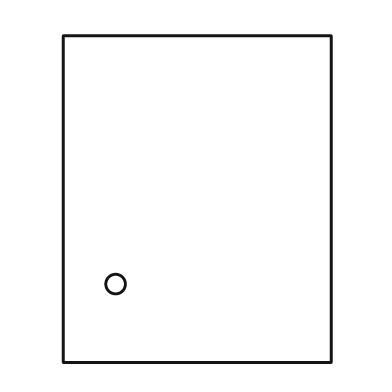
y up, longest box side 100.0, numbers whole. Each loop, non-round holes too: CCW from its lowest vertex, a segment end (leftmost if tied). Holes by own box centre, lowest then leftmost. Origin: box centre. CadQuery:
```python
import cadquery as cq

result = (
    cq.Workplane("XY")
    .moveTo(-41.0, -50.0)
    .lineTo(41.0, -50.0)
    .lineTo(41.0, 50.0)
    .lineTo(-41.0, 50.0)
    .close()
    .moveTo(-25.0, -26.0)
    .circle(3.0)
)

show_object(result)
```